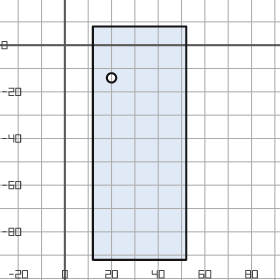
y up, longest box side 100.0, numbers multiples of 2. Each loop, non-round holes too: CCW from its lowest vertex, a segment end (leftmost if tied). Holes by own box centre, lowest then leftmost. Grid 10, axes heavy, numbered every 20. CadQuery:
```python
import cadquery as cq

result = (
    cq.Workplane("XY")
    .moveTo(12.0, -92.0)
    .lineTo(52.0, -92.0)
    .lineTo(52.0, 8.0)
    .lineTo(12.0, 8.0)
    .close()
    .moveTo(20.0, -14.0)
    .circle(2.0)
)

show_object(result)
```